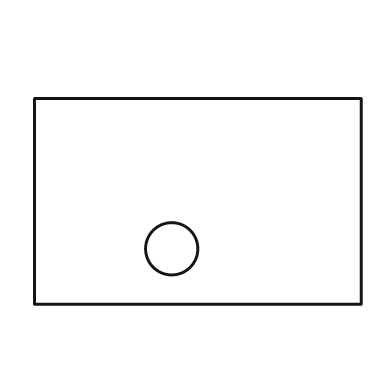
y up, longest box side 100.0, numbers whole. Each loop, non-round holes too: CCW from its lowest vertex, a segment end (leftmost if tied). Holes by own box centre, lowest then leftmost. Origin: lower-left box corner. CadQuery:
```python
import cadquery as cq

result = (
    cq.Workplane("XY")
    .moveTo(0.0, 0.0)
    .lineTo(100.0, 0.0)
    .lineTo(100.0, 63.0)
    .lineTo(0.0, 63.0)
    .close()
    .moveTo(42.0, 17.0)
    .circle(8.0)
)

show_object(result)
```